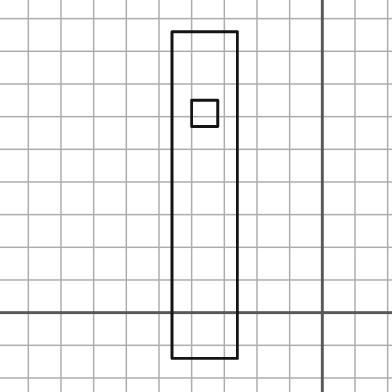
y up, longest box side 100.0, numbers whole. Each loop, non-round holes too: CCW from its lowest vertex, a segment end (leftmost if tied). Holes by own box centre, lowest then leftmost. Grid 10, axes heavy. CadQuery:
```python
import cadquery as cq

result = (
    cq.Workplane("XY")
    .moveTo(-46.0, -14.0)
    .lineTo(-26.0, -14.0)
    .lineTo(-26.0, 86.0)
    .lineTo(-46.0, 86.0)
    .close()
    .moveTo(-40.0, 57.0)
    .lineTo(-32.0, 57.0)
    .lineTo(-32.0, 65.0)
    .lineTo(-40.0, 65.0)
    .close()
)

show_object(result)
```